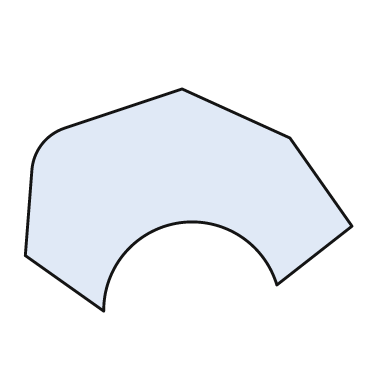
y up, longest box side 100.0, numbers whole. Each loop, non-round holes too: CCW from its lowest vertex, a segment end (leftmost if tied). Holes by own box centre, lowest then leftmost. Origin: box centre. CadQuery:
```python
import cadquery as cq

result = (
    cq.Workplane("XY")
    .moveTo(-26.0, -34.0)
    .threePointArc((-3.0, -7.0), (27.0, -26.0))
    .lineTo(50.0, -8.0)
    .lineTo(31.0, 19.0)
    .lineTo(-2.0, 34.0)
    .lineTo(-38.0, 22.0)
    .threePointArc((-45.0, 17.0), (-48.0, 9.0))
    .lineTo(-50.0, -17.0)
    .close()
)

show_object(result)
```